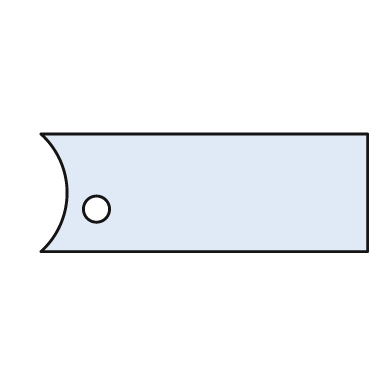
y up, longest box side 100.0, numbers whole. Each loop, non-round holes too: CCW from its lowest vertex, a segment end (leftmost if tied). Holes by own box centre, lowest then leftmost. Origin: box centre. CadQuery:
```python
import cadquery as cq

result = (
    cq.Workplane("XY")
    .moveTo(-50.0, -18.0)
    .lineTo(50.0, -18.0)
    .lineTo(50.0, 18.0)
    .lineTo(-50.0, 18.0)
    .threePointArc((-42.0, 0.0), (-50.0, -18.0))
    .close()
    .moveTo(-33.0, -5.0)
    .circle(4.0)
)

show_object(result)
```